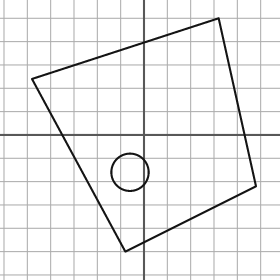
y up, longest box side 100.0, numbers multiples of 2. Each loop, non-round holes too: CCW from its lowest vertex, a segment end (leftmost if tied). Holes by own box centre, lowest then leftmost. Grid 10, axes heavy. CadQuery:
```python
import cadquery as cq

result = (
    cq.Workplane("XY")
    .moveTo(-8.0, -50.0)
    .lineTo(48.0, -22.0)
    .lineTo(32.0, 50.0)
    .lineTo(-48.0, 24.0)
    .close()
    .moveTo(-6.0, -16.0)
    .circle(8.0)
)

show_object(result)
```